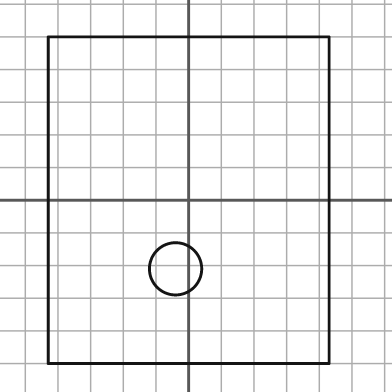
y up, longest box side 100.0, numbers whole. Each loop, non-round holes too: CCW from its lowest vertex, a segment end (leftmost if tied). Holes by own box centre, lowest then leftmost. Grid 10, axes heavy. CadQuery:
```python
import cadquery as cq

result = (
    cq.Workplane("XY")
    .moveTo(-43.0, -50.0)
    .lineTo(43.0, -50.0)
    .lineTo(43.0, 50.0)
    .lineTo(-43.0, 50.0)
    .close()
    .moveTo(-4.0, -21.0)
    .circle(8.0)
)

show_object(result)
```